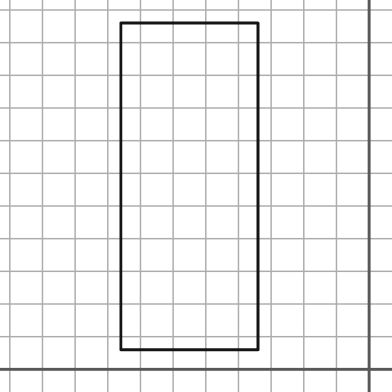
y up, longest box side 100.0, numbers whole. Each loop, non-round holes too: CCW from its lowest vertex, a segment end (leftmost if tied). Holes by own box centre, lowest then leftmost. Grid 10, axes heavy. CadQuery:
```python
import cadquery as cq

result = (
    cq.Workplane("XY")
    .moveTo(-76.0, 6.0)
    .lineTo(-34.0, 6.0)
    .lineTo(-34.0, 106.0)
    .lineTo(-76.0, 106.0)
    .close()
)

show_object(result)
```